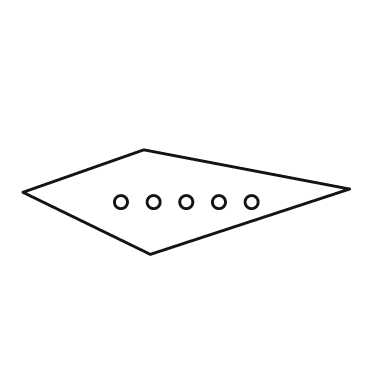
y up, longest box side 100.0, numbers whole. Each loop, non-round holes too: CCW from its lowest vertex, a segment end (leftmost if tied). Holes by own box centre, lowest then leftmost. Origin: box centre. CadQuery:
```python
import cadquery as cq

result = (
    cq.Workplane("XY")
    .moveTo(-11.0, -16.0)
    .lineTo(50.0, 4.0)
    .lineTo(-13.0, 16.0)
    .lineTo(-50.0, 3.0)
    .close()
    .moveTo(-20.0, 0.0)
    .circle(2.0)
    .moveTo(-10.0, 0.0)
    .circle(2.0)
    .moveTo(0.0, 0.0)
    .circle(2.0)
    .moveTo(10.0, 0.0)
    .circle(2.0)
    .moveTo(20.0, 0.0)
    .circle(2.0)
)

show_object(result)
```